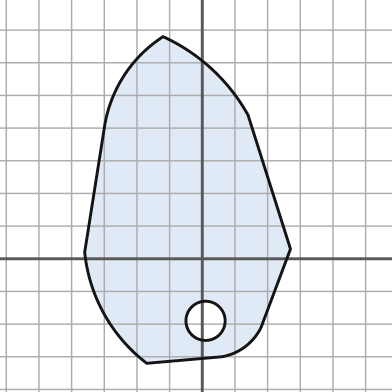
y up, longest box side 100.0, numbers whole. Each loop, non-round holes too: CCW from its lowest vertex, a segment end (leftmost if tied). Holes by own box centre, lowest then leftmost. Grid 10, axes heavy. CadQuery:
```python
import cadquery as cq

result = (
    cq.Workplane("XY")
    .moveTo(-17.0, -32.0)
    .lineTo(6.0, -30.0)
    .threePointArc((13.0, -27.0), (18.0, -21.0))
    .lineTo(27.0, 3.0)
    .lineTo(14.0, 44.0)
    .threePointArc((3.0, 58.0), (-12.0, 68.0))
    .threePointArc((-24.0, 56.0), (-30.0, 40.0))
    .lineTo(-36.0, 2.0)
    .threePointArc((-30.0, -17.0), (-17.0, -32.0))
    .close()
    .moveTo(1.0, -19.0)
    .circle(6.0)
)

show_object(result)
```